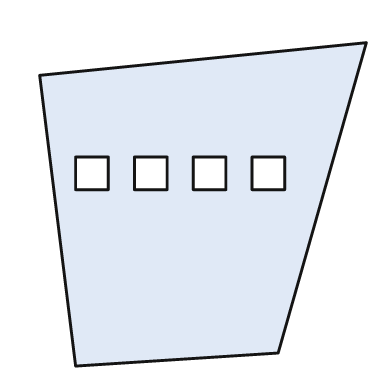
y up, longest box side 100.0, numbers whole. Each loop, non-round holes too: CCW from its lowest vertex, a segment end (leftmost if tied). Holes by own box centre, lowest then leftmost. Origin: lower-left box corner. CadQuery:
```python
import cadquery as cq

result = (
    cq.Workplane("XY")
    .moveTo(11.0, 0.0)
    .lineTo(73.0, 4.0)
    .lineTo(100.0, 99.0)
    .lineTo(0.0, 89.0)
    .close()
    .moveTo(11.0, 54.0)
    .lineTo(21.0, 54.0)
    .lineTo(21.0, 64.0)
    .lineTo(11.0, 64.0)
    .close()
    .moveTo(29.0, 54.0)
    .lineTo(39.0, 54.0)
    .lineTo(39.0, 64.0)
    .lineTo(29.0, 64.0)
    .close()
    .moveTo(47.0, 54.0)
    .lineTo(57.0, 54.0)
    .lineTo(57.0, 64.0)
    .lineTo(47.0, 64.0)
    .close()
    .moveTo(65.0, 54.0)
    .lineTo(75.0, 54.0)
    .lineTo(75.0, 64.0)
    .lineTo(65.0, 64.0)
    .close()
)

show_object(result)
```